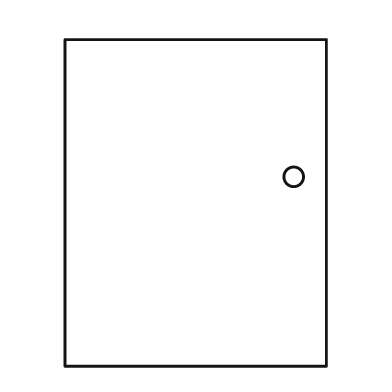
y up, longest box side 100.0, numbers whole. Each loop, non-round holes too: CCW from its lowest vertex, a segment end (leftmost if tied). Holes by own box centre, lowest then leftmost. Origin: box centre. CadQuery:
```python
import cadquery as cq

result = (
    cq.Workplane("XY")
    .moveTo(-40.0, -50.0)
    .lineTo(40.0, -50.0)
    .lineTo(40.0, 50.0)
    .lineTo(-40.0, 50.0)
    .close()
    .moveTo(30.0, 8.0)
    .circle(3.0)
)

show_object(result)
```